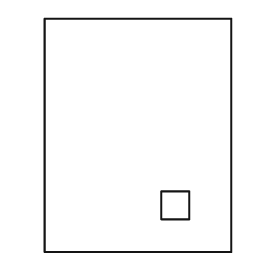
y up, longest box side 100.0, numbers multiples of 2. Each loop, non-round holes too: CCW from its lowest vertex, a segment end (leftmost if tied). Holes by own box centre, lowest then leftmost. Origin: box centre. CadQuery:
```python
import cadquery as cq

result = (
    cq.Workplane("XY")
    .moveTo(-40.0, -50.0)
    .lineTo(40.0, -50.0)
    .lineTo(40.0, 50.0)
    .lineTo(-40.0, 50.0)
    .close()
    .moveTo(10.0, -36.0)
    .lineTo(22.0, -36.0)
    .lineTo(22.0, -24.0)
    .lineTo(10.0, -24.0)
    .close()
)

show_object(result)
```